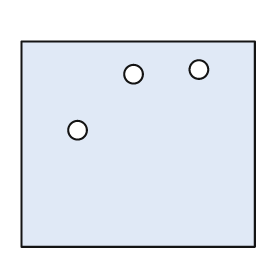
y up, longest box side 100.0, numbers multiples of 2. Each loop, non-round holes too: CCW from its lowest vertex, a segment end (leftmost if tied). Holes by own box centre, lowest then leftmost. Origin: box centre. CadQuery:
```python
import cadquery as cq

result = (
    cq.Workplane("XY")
    .moveTo(-50.0, -44.0)
    .lineTo(50.0, -44.0)
    .lineTo(50.0, 44.0)
    .lineTo(-50.0, 44.0)
    .close()
    .moveTo(-26.0, 6.0)
    .circle(4.0)
    .moveTo(-2.0, 30.0)
    .circle(4.0)
    .moveTo(26.0, 32.0)
    .circle(4.0)
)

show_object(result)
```